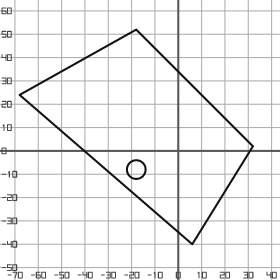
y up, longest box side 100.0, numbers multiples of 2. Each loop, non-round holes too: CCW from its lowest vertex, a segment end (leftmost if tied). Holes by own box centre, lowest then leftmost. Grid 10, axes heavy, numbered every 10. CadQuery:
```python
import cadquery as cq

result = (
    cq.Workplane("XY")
    .moveTo(6.0, -40.0)
    .lineTo(32.0, 2.0)
    .lineTo(-18.0, 52.0)
    .lineTo(-68.0, 24.0)
    .close()
    .moveTo(-18.0, -8.0)
    .circle(4.0)
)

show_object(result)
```